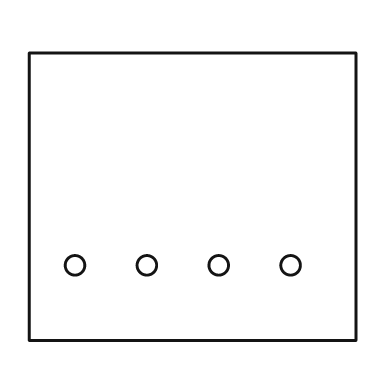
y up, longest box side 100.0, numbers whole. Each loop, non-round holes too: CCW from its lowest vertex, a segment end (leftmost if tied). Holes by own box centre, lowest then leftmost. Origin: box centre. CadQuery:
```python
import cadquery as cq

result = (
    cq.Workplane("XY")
    .moveTo(-50.0, -44.0)
    .lineTo(50.0, -44.0)
    .lineTo(50.0, 44.0)
    .lineTo(-50.0, 44.0)
    .close()
    .moveTo(-36.0, -21.0)
    .circle(3.0)
    .moveTo(-14.0, -21.0)
    .circle(3.0)
    .moveTo(8.0, -21.0)
    .circle(3.0)
    .moveTo(30.0, -21.0)
    .circle(3.0)
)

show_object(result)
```